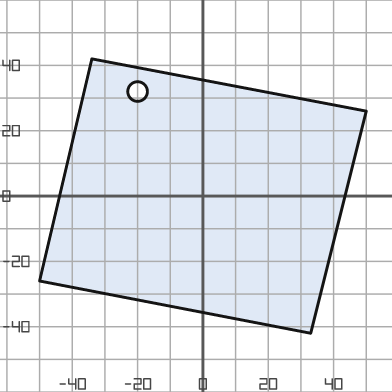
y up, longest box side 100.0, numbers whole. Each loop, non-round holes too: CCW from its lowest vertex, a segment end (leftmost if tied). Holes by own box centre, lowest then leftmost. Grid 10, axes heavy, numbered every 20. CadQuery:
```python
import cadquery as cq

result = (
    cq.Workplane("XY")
    .moveTo(33.0, -42.0)
    .lineTo(50.0, 26.0)
    .lineTo(-34.0, 42.0)
    .lineTo(-50.0, -26.0)
    .close()
    .moveTo(-20.0, 32.0)
    .circle(3.0)
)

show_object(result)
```